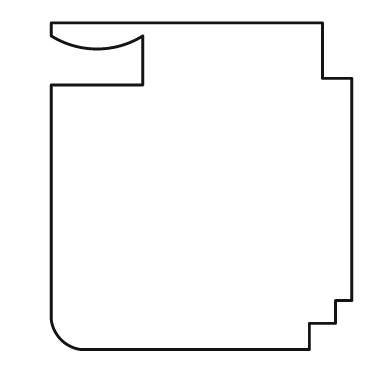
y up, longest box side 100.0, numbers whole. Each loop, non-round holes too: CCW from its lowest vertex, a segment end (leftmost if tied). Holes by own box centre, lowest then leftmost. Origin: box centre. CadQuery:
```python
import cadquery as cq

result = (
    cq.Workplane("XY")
    .moveTo(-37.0, -50.0)
    .lineTo(33.0, -50.0)
    .lineTo(33.0, -42.0)
    .lineTo(41.0, -42.0)
    .lineTo(41.0, -35.0)
    .lineTo(46.0, -35.0)
    .lineTo(46.0, 33.0)
    .lineTo(37.0, 33.0)
    .lineTo(37.0, 50.0)
    .lineTo(-46.0, 50.0)
    .lineTo(-46.0, 46.0)
    .threePointArc((-32.0, 42.0), (-18.0, 46.0))
    .lineTo(-18.0, 31.0)
    .lineTo(-46.0, 31.0)
    .lineTo(-46.0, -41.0)
    .threePointArc((-43.0, -47.0), (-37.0, -50.0))
    .close()
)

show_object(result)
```